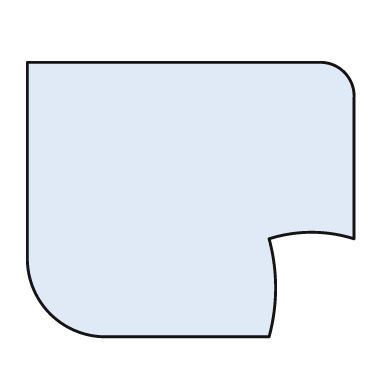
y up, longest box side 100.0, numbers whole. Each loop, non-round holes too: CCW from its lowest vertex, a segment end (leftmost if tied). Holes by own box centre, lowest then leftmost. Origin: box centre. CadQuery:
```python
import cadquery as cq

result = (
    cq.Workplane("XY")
    .moveTo(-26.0, -42.0)
    .lineTo(24.0, -42.0)
    .threePointArc((26.0, -27.0), (24.0, -12.0))
    .threePointArc((37.0, -10.0), (50.0, -12.0))
    .lineTo(50.0, 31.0)
    .threePointArc((47.0, 39.0), (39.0, 42.0))
    .lineTo(-50.0, 42.0)
    .lineTo(-50.0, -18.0)
    .threePointArc((-43.0, -35.0), (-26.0, -42.0))
    .close()
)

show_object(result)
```